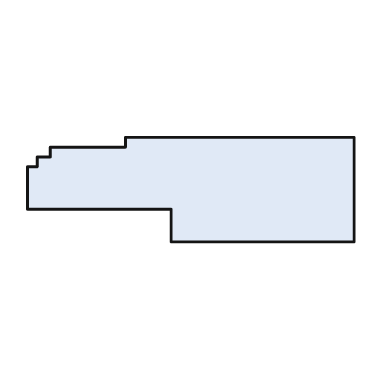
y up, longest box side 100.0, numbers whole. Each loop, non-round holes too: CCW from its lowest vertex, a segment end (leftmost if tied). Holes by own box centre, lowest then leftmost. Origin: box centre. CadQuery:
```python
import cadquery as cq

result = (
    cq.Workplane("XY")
    .moveTo(-6.0, -16.0)
    .lineTo(50.0, -16.0)
    .lineTo(50.0, 16.0)
    .lineTo(-20.0, 16.0)
    .lineTo(-20.0, 13.0)
    .lineTo(-43.0, 13.0)
    .lineTo(-43.0, 10.0)
    .lineTo(-47.0, 10.0)
    .lineTo(-47.0, 7.0)
    .lineTo(-50.0, 7.0)
    .lineTo(-50.0, -6.0)
    .lineTo(-6.0, -6.0)
    .close()
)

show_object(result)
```